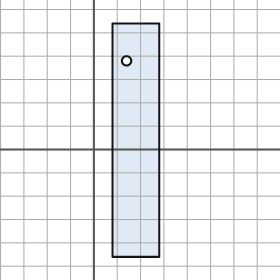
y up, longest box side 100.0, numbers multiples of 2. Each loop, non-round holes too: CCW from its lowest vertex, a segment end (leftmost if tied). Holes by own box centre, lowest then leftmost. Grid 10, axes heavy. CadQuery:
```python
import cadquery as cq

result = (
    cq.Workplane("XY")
    .moveTo(8.0, -46.0)
    .lineTo(28.0, -46.0)
    .lineTo(28.0, 54.0)
    .lineTo(8.0, 54.0)
    .close()
    .moveTo(14.0, 38.0)
    .circle(2.0)
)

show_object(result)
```